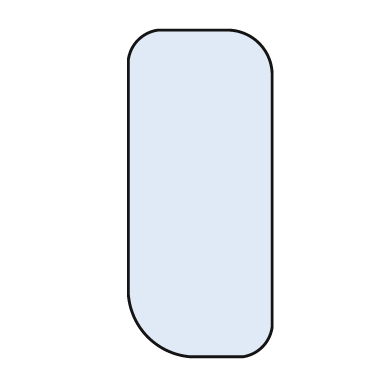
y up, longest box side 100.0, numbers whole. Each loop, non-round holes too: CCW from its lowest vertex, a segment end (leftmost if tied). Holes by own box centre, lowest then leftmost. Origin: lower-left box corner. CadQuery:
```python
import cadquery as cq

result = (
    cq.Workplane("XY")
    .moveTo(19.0, 0.0)
    .lineTo(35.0, 0.0)
    .threePointArc((41.0, 3.0), (44.0, 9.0))
    .lineTo(44.0, 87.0)
    .threePointArc((40.0, 96.0), (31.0, 100.0))
    .lineTo(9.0, 100.0)
    .threePointArc((3.0, 97.0), (0.0, 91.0))
    .lineTo(0.0, 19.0)
    .threePointArc((6.0, 6.0), (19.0, 0.0))
    .close()
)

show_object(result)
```